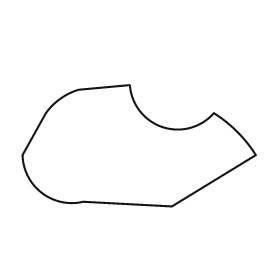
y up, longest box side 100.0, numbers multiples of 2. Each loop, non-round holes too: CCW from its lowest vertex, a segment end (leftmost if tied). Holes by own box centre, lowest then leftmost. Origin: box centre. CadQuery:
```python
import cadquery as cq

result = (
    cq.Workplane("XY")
    .moveTo(14.0, -26.0)
    .lineTo(50.0, -4.0)
    .threePointArc((42.0, 6.0), (32.0, 14.0))
    .threePointArc((10.0, 8.0), (-4.0, 26.0))
    .lineTo(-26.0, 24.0)
    .threePointArc((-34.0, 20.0), (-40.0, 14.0))
    .lineTo(-50.0, -4.0)
    .threePointArc((-42.0, -20.0), (-24.0, -24.0))
    .close()
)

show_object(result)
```